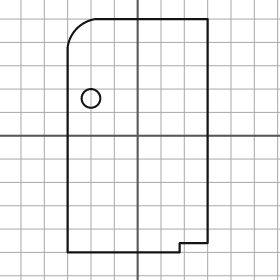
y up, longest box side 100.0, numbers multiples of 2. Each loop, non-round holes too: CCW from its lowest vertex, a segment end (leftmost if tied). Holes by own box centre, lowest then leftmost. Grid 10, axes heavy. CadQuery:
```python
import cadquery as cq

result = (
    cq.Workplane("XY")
    .moveTo(-30.0, -50.0)
    .lineTo(18.0, -50.0)
    .lineTo(18.0, -46.0)
    .lineTo(30.0, -46.0)
    .lineTo(30.0, 50.0)
    .lineTo(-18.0, 50.0)
    .threePointArc((-26.0, 46.0), (-30.0, 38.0))
    .close()
    .moveTo(-20.0, 16.0)
    .circle(4.0)
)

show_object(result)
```